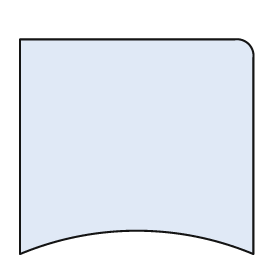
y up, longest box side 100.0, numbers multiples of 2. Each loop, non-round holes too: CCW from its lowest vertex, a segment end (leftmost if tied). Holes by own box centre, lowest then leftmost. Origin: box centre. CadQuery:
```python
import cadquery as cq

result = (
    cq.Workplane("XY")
    .moveTo(-50.0, -46.0)
    .threePointArc((0.0, -36.0), (50.0, -46.0))
    .lineTo(50.0, 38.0)
    .threePointArc((48.0, 44.0), (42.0, 46.0))
    .lineTo(-50.0, 46.0)
    .close()
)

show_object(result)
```